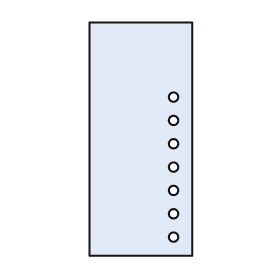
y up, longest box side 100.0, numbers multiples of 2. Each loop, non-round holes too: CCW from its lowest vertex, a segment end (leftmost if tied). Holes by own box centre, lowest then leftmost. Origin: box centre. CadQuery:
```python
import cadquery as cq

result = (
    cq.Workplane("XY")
    .moveTo(-22.0, -50.0)
    .lineTo(22.0, -50.0)
    .lineTo(22.0, 50.0)
    .lineTo(-22.0, 50.0)
    .close()
    .moveTo(14.0, -42.0)
    .circle(2.0)
    .moveTo(14.0, -32.0)
    .circle(2.0)
    .moveTo(14.0, -22.0)
    .circle(2.0)
    .moveTo(14.0, -12.0)
    .circle(2.0)
    .moveTo(14.0, -2.0)
    .circle(2.0)
    .moveTo(14.0, 8.0)
    .circle(2.0)
    .moveTo(14.0, 18.0)
    .circle(2.0)
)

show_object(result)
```